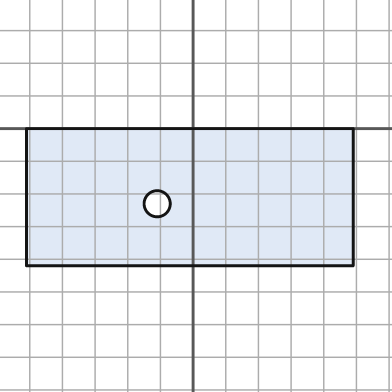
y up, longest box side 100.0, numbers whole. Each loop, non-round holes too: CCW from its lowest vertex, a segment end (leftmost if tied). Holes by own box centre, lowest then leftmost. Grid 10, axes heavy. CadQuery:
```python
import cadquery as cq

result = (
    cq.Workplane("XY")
    .moveTo(-51.0, -42.0)
    .lineTo(49.0, -42.0)
    .lineTo(49.0, 0.0)
    .lineTo(-51.0, 0.0)
    .close()
    .moveTo(-11.0, -23.0)
    .circle(4.0)
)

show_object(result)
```